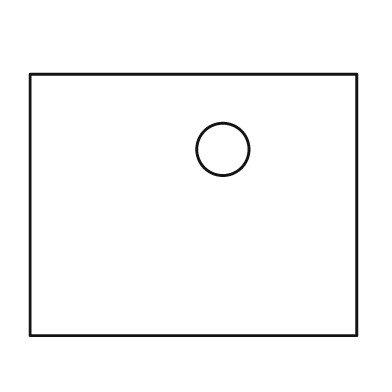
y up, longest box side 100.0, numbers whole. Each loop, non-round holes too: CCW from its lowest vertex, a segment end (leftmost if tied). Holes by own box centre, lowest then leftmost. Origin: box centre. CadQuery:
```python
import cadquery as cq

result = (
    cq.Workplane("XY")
    .moveTo(-50.0, -40.0)
    .lineTo(50.0, -40.0)
    .lineTo(50.0, 40.0)
    .lineTo(-50.0, 40.0)
    .close()
    .moveTo(9.0, 17.0)
    .circle(8.0)
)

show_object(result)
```